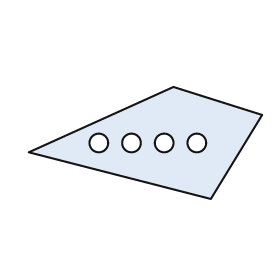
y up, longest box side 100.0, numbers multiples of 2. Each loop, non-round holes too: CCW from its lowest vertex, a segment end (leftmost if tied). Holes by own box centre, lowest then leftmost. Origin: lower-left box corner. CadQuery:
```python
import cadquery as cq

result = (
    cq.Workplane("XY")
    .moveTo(78.0, 0.0)
    .lineTo(100.0, 36.0)
    .lineTo(62.0, 48.0)
    .lineTo(0.0, 20.0)
    .close()
    .moveTo(30.0, 24.0)
    .circle(4.0)
    .moveTo(44.0, 24.0)
    .circle(4.0)
    .moveTo(58.0, 24.0)
    .circle(4.0)
    .moveTo(72.0, 24.0)
    .circle(4.0)
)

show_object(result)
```